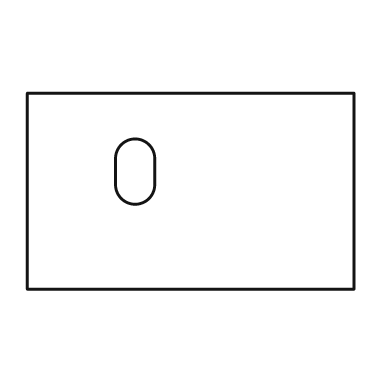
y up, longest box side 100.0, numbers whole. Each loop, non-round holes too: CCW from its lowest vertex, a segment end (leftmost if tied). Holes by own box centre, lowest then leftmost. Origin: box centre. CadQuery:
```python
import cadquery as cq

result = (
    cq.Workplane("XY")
    .moveTo(-50.0, -30.0)
    .lineTo(50.0, -30.0)
    .lineTo(50.0, 30.0)
    .lineTo(-50.0, 30.0)
    .close()
    .moveTo(-23.0, 2.0)
    .threePointArc((-17.0, -4.0), (-11.0, 2.0))
    .lineTo(-11.0, 10.0)
    .threePointArc((-17.0, 16.0), (-23.0, 10.0))
    .close()
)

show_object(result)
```